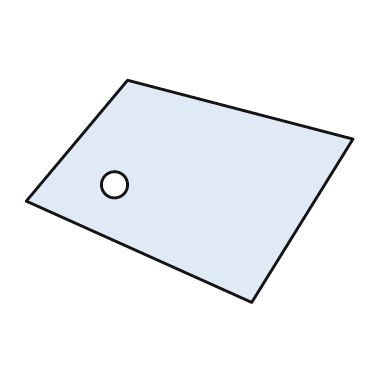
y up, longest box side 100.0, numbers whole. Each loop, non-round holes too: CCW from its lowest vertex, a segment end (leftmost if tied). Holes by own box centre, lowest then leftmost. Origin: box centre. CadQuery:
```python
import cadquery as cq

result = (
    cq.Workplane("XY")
    .moveTo(19.0, -34.0)
    .lineTo(50.0, 16.0)
    .lineTo(-19.0, 34.0)
    .lineTo(-50.0, -3.0)
    .close()
    .moveTo(-23.0, 2.0)
    .circle(4.0)
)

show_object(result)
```